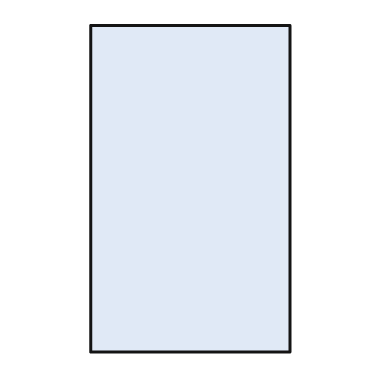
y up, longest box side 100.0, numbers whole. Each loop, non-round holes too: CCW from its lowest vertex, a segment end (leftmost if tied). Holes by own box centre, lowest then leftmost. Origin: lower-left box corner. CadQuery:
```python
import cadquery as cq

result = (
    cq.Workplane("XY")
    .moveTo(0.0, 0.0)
    .lineTo(61.0, 0.0)
    .lineTo(61.0, 100.0)
    .lineTo(0.0, 100.0)
    .close()
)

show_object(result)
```